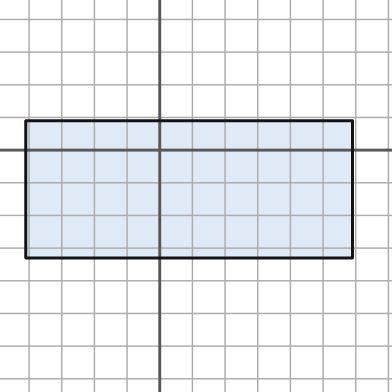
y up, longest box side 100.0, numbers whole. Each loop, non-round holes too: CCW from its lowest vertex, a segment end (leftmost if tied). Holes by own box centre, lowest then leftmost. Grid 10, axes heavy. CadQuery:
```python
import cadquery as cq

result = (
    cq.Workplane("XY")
    .moveTo(-41.0, -33.0)
    .lineTo(59.0, -33.0)
    .lineTo(59.0, 9.0)
    .lineTo(-41.0, 9.0)
    .close()
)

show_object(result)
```